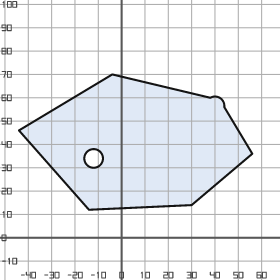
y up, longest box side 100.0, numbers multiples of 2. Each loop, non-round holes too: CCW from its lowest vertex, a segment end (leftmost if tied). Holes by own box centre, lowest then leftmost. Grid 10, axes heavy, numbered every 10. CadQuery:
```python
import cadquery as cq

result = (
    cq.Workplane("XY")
    .moveTo(-14.0, 12.0)
    .lineTo(30.0, 14.0)
    .lineTo(56.0, 36.0)
    .lineTo(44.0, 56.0)
    .threePointArc((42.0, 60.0), (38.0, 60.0))
    .lineTo(-4.0, 70.0)
    .lineTo(-44.0, 46.0)
    .close()
    .moveTo(-12.0, 34.0)
    .circle(4.0)
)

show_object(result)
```